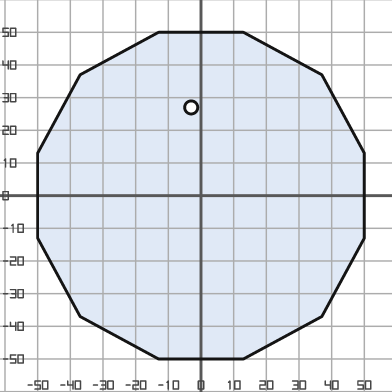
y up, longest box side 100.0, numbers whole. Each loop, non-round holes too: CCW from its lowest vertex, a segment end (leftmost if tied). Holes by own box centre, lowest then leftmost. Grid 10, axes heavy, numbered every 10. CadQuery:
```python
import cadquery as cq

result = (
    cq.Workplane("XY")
    .moveTo(-13.0, -50.0)
    .lineTo(13.0, -50.0)
    .lineTo(37.0, -37.0)
    .lineTo(50.0, -13.0)
    .lineTo(50.0, 13.0)
    .lineTo(37.0, 37.0)
    .lineTo(13.0, 50.0)
    .lineTo(-13.0, 50.0)
    .lineTo(-37.0, 37.0)
    .lineTo(-50.0, 13.0)
    .lineTo(-50.0, -13.0)
    .lineTo(-37.0, -37.0)
    .close()
    .moveTo(-3.0, 27.0)
    .circle(2.0)
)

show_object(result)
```